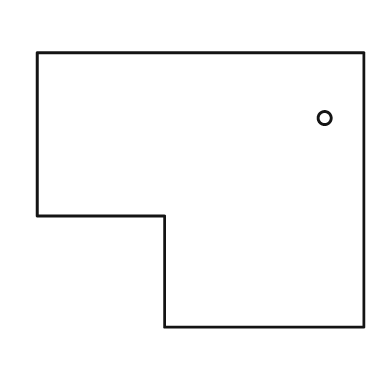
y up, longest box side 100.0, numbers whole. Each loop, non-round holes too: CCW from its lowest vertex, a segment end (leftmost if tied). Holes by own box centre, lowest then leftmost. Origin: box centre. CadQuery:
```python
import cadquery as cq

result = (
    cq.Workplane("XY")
    .moveTo(-11.0, -42.0)
    .lineTo(50.0, -42.0)
    .lineTo(50.0, 42.0)
    .lineTo(-50.0, 42.0)
    .lineTo(-50.0, -8.0)
    .lineTo(-11.0, -8.0)
    .close()
    .moveTo(38.0, 22.0)
    .circle(2.0)
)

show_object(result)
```